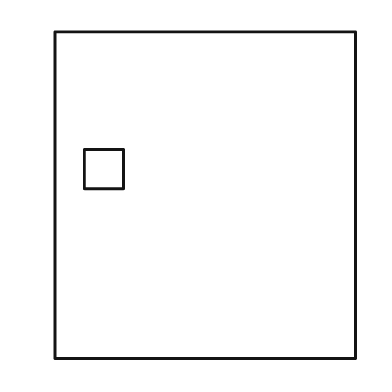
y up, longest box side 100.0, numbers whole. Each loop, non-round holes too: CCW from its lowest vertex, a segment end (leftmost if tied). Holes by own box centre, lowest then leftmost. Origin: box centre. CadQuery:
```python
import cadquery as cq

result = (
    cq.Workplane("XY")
    .moveTo(-46.0, -50.0)
    .lineTo(46.0, -50.0)
    .lineTo(46.0, 50.0)
    .lineTo(-46.0, 50.0)
    .close()
    .moveTo(-37.0, 2.0)
    .lineTo(-25.0, 2.0)
    .lineTo(-25.0, 14.0)
    .lineTo(-37.0, 14.0)
    .close()
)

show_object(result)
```